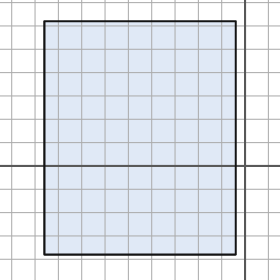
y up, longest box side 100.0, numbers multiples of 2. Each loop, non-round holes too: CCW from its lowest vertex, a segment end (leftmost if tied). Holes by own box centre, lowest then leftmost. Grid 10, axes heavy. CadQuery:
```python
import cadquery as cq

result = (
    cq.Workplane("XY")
    .moveTo(-86.0, -38.0)
    .lineTo(-4.0, -38.0)
    .lineTo(-4.0, 62.0)
    .lineTo(-86.0, 62.0)
    .close()
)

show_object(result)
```